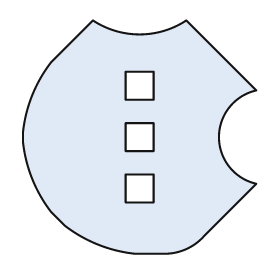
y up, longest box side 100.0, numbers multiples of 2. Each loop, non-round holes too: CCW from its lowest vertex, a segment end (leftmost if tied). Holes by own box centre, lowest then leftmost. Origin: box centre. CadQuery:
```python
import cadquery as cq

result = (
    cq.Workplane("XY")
    .moveTo(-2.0, -50.0)
    .lineTo(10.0, -50.0)
    .threePointArc((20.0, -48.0), (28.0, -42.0))
    .lineTo(50.0, -20.0)
    .threePointArc((34.0, 0.0), (50.0, 20.0))
    .lineTo(20.0, 50.0)
    .threePointArc((0.0, 44.0), (-20.0, 50.0))
    .lineTo(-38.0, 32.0)
    .threePointArc((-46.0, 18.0), (-50.0, 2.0))
    .lineTo(-50.0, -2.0)
    .threePointArc((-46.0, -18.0), (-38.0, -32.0))
    .lineTo(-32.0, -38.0)
    .threePointArc((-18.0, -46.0), (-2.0, -50.0))
    .close()
    .moveTo(-6.0, -28.0)
    .lineTo(6.0, -28.0)
    .lineTo(6.0, -16.0)
    .lineTo(-6.0, -16.0)
    .close()
    .moveTo(-6.0, -6.0)
    .lineTo(6.0, -6.0)
    .lineTo(6.0, 6.0)
    .lineTo(-6.0, 6.0)
    .close()
    .moveTo(-6.0, 16.0)
    .lineTo(6.0, 16.0)
    .lineTo(6.0, 28.0)
    .lineTo(-6.0, 28.0)
    .close()
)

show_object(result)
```